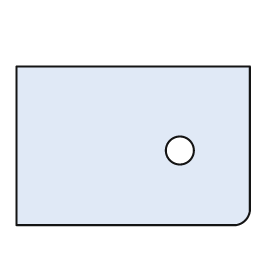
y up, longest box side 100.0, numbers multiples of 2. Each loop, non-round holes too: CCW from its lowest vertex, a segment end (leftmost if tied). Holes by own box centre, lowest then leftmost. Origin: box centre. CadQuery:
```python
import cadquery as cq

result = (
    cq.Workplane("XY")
    .moveTo(-50.0, -34.0)
    .lineTo(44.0, -34.0)
    .threePointArc((48.0, -32.0), (50.0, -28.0))
    .lineTo(50.0, 34.0)
    .lineTo(-50.0, 34.0)
    .close()
    .moveTo(20.0, -2.0)
    .circle(6.0)
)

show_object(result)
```